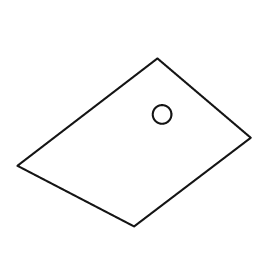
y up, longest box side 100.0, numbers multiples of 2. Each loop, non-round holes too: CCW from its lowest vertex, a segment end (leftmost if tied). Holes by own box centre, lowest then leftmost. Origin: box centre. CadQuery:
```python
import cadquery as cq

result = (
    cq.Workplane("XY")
    .moveTo(0.0, -36.0)
    .lineTo(50.0, 2.0)
    .lineTo(10.0, 36.0)
    .lineTo(-50.0, -10.0)
    .close()
    .moveTo(12.0, 12.0)
    .circle(4.0)
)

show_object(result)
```